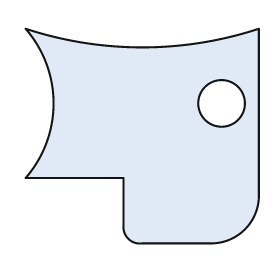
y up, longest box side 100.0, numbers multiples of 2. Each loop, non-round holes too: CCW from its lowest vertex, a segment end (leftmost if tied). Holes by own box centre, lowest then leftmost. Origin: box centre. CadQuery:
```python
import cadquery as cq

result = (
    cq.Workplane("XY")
    .moveTo(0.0, -46.0)
    .lineTo(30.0, -46.0)
    .threePointArc((44.0, -40.0), (50.0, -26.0))
    .lineTo(50.0, 46.0)
    .threePointArc((0.0, 38.0), (-50.0, 46.0))
    .threePointArc((-38.0, 14.0), (-50.0, -18.0))
    .lineTo(-8.0, -18.0)
    .lineTo(-8.0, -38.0)
    .threePointArc((-6.0, -44.0), (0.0, -46.0))
    .close()
    .moveTo(34.0, 14.0)
    .circle(10.0)
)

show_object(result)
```